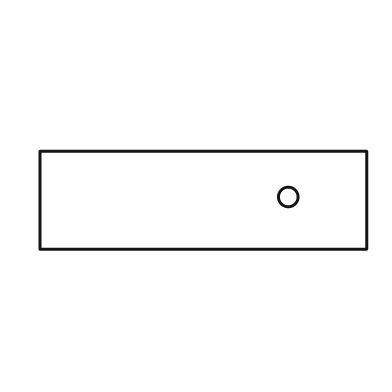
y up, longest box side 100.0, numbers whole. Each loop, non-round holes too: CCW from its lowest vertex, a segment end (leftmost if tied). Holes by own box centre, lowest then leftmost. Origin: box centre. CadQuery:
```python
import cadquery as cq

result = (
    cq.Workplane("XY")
    .moveTo(-50.0, -15.0)
    .lineTo(50.0, -15.0)
    .lineTo(50.0, 15.0)
    .lineTo(-50.0, 15.0)
    .close()
    .moveTo(26.0, 1.0)
    .circle(3.0)
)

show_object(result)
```